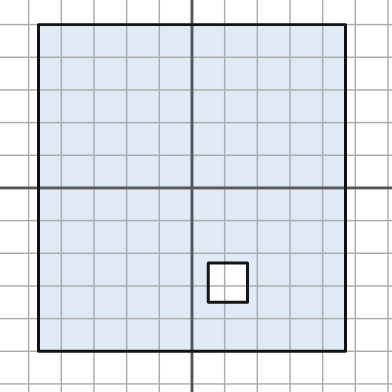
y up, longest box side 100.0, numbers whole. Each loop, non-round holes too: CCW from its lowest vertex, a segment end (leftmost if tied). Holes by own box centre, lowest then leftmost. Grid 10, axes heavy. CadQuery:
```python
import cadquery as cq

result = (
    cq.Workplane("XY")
    .moveTo(-47.0, -50.0)
    .lineTo(47.0, -50.0)
    .lineTo(47.0, 50.0)
    .lineTo(-47.0, 50.0)
    .close()
    .moveTo(5.0, -35.0)
    .lineTo(17.0, -35.0)
    .lineTo(17.0, -23.0)
    .lineTo(5.0, -23.0)
    .close()
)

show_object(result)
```